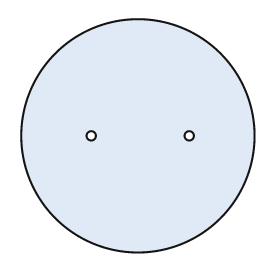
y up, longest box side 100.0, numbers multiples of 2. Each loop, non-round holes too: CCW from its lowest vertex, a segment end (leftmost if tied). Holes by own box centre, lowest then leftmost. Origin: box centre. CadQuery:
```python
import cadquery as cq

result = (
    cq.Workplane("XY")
    .moveTo(0.0, 0.0)
    .circle(50.0)
    .moveTo(-20.0, 0.0)
    .circle(2.0)
    .moveTo(22.0, 0.0)
    .circle(2.0)
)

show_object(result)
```